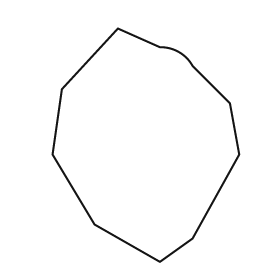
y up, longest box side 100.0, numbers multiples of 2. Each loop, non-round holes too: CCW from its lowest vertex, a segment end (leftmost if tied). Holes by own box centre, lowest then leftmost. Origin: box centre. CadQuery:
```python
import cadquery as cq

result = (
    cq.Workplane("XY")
    .moveTo(6.0, -50.0)
    .lineTo(20.0, -40.0)
    .lineTo(40.0, -4.0)
    .lineTo(36.0, 18.0)
    .lineTo(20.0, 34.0)
    .threePointArc((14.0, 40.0), (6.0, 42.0))
    .lineTo(-12.0, 50.0)
    .lineTo(-36.0, 24.0)
    .lineTo(-40.0, -4.0)
    .lineTo(-22.0, -34.0)
    .close()
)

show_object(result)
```